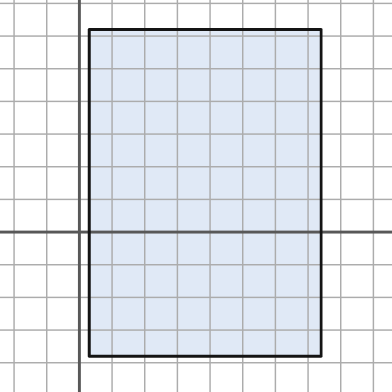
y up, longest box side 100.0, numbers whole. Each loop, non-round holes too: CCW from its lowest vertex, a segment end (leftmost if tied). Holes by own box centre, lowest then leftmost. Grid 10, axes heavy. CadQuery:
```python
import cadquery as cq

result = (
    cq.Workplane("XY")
    .moveTo(3.0, -38.0)
    .lineTo(74.0, -38.0)
    .lineTo(74.0, 62.0)
    .lineTo(3.0, 62.0)
    .close()
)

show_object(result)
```